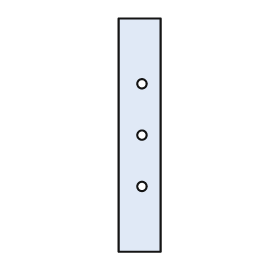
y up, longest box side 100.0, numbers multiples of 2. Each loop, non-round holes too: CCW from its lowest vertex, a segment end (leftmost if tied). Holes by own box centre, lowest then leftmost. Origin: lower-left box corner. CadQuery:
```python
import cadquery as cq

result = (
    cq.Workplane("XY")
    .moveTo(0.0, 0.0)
    .lineTo(18.0, 0.0)
    .lineTo(18.0, 100.0)
    .lineTo(0.0, 100.0)
    .close()
    .moveTo(10.0, 28.0)
    .circle(2.0)
    .moveTo(10.0, 50.0)
    .circle(2.0)
    .moveTo(10.0, 72.0)
    .circle(2.0)
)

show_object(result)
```